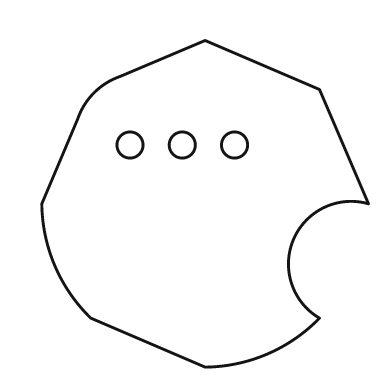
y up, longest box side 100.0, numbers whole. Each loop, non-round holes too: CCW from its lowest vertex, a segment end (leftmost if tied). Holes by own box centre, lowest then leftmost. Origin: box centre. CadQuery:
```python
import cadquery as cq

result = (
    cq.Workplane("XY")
    .moveTo(0.0, -50.0)
    .threePointArc((19.0, -46.0), (35.0, -35.0))
    .threePointArc((27.0, -11.0), (50.0, 0.0))
    .lineTo(35.0, 35.0)
    .lineTo(0.0, 50.0)
    .lineTo(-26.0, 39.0)
    .threePointArc((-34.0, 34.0), (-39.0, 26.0))
    .lineTo(-50.0, 0.0)
    .threePointArc((-46.0, -19.0), (-35.0, -35.0))
    .close()
    .moveTo(-23.0, 18.0)
    .circle(4.0)
    .moveTo(-7.0, 18.0)
    .circle(4.0)
    .moveTo(9.0, 18.0)
    .circle(4.0)
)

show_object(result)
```